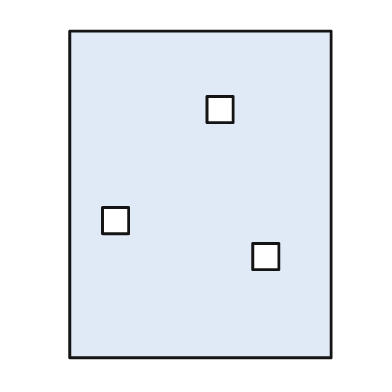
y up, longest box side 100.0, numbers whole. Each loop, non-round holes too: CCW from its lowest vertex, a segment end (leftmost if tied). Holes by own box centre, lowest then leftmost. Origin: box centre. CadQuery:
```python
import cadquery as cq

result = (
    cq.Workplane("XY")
    .moveTo(-40.0, -50.0)
    .lineTo(40.0, -50.0)
    .lineTo(40.0, 50.0)
    .lineTo(-40.0, 50.0)
    .close()
    .moveTo(16.0, -23.0)
    .lineTo(24.0, -23.0)
    .lineTo(24.0, -15.0)
    .lineTo(16.0, -15.0)
    .close()
    .moveTo(-30.0, -12.0)
    .lineTo(-22.0, -12.0)
    .lineTo(-22.0, -4.0)
    .lineTo(-30.0, -4.0)
    .close()
    .moveTo(2.0, 22.0)
    .lineTo(10.0, 22.0)
    .lineTo(10.0, 30.0)
    .lineTo(2.0, 30.0)
    .close()
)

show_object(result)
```